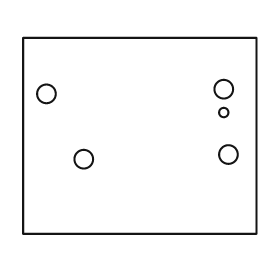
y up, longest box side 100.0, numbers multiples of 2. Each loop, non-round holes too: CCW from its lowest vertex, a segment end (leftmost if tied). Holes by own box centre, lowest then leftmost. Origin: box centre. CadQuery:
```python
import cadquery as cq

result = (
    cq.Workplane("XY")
    .moveTo(-50.0, -42.0)
    .lineTo(50.0, -42.0)
    .lineTo(50.0, 42.0)
    .lineTo(-50.0, 42.0)
    .close()
    .moveTo(-24.0, -10.0)
    .circle(4.0)
    .moveTo(38.0, -8.0)
    .circle(4.0)
    .moveTo(36.0, 10.0)
    .circle(2.0)
    .moveTo(-40.0, 18.0)
    .circle(4.0)
    .moveTo(36.0, 20.0)
    .circle(4.0)
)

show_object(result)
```